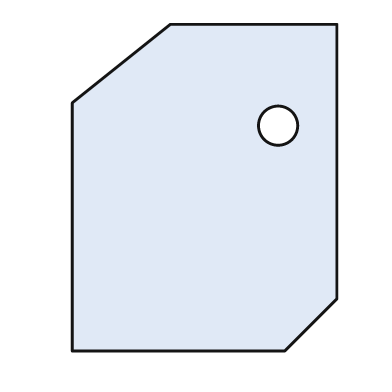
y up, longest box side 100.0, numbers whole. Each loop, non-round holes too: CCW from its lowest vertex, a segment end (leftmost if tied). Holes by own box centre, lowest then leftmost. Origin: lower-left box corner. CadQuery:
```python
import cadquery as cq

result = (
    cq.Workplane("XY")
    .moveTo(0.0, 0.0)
    .lineTo(65.0, 0.0)
    .lineTo(81.0, 16.0)
    .lineTo(81.0, 100.0)
    .lineTo(30.0, 100.0)
    .lineTo(0.0, 76.0)
    .close()
    .moveTo(63.0, 69.0)
    .circle(6.0)
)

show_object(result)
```